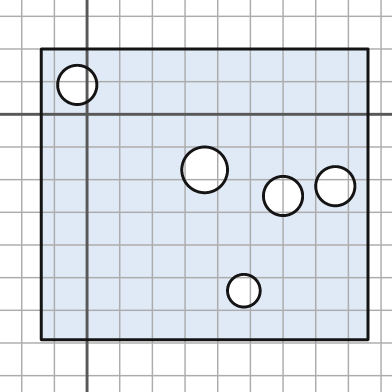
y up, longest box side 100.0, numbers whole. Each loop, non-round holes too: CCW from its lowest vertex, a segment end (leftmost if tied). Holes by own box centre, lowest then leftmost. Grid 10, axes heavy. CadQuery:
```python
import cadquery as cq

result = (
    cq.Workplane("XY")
    .moveTo(-14.0, -69.0)
    .lineTo(86.0, -69.0)
    .lineTo(86.0, 20.0)
    .lineTo(-14.0, 20.0)
    .close()
    .moveTo(48.0, -54.0)
    .circle(5.0)
    .moveTo(60.0, -25.0)
    .circle(6.0)
    .moveTo(76.0, -22.0)
    .circle(6.0)
    .moveTo(36.0, -17.0)
    .circle(7.0)
    .moveTo(-3.0, 9.0)
    .circle(6.0)
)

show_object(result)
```